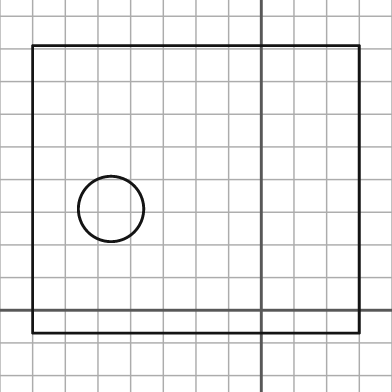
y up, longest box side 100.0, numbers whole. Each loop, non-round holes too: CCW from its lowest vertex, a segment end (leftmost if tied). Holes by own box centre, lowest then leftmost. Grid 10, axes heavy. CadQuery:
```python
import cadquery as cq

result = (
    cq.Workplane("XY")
    .moveTo(-70.0, -7.0)
    .lineTo(30.0, -7.0)
    .lineTo(30.0, 81.0)
    .lineTo(-70.0, 81.0)
    .close()
    .moveTo(-46.0, 31.0)
    .circle(10.0)
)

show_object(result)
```